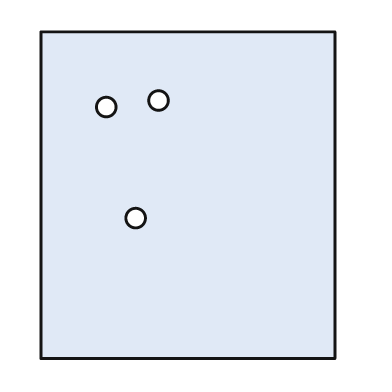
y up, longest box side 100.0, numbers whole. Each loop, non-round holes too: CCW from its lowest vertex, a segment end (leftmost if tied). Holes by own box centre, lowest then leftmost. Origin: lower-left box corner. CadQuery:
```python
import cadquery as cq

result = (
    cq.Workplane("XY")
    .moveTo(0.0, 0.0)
    .lineTo(90.0, 0.0)
    .lineTo(90.0, 100.0)
    .lineTo(0.0, 100.0)
    .close()
    .moveTo(29.0, 43.0)
    .circle(3.0)
    .moveTo(20.0, 77.0)
    .circle(3.0)
    .moveTo(36.0, 79.0)
    .circle(3.0)
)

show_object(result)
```